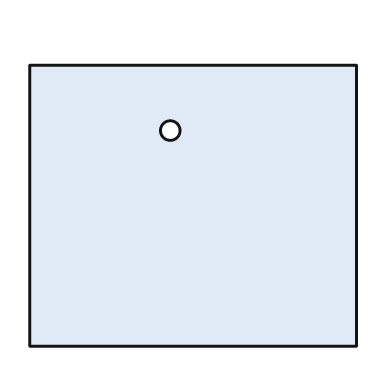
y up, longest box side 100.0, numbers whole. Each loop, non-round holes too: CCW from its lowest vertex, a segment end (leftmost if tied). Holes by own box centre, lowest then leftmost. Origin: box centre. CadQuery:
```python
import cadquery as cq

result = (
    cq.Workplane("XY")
    .moveTo(-50.0, -43.0)
    .lineTo(50.0, -43.0)
    .lineTo(50.0, 43.0)
    .lineTo(-50.0, 43.0)
    .close()
    .moveTo(-7.0, 23.0)
    .circle(3.0)
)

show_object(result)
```